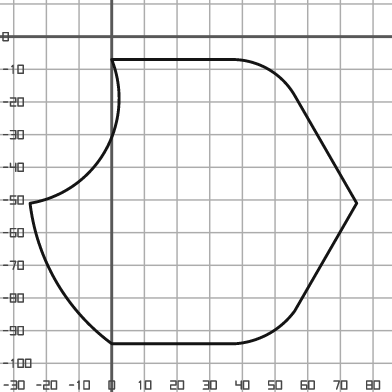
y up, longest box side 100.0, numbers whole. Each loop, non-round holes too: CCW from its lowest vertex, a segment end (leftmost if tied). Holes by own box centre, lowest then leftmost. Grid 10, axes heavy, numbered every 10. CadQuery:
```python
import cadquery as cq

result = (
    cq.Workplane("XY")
    .moveTo(0.0, -94.0)
    .lineTo(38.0, -94.0)
    .threePointArc((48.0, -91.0), (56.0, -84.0))
    .lineTo(75.0, -51.0)
    .lineTo(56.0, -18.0)
    .threePointArc((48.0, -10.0), (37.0, -7.0))
    .lineTo(0.0, -7.0)
    .threePointArc((-2.0, -35.0), (-25.0, -51.0))
    .threePointArc((-17.0, -75.0), (0.0, -94.0))
    .close()
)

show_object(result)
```